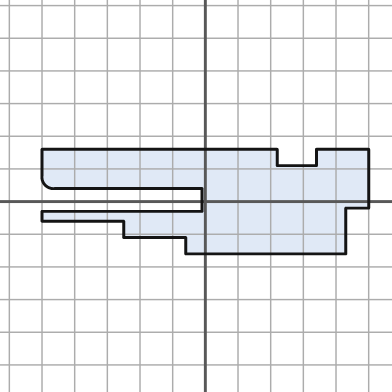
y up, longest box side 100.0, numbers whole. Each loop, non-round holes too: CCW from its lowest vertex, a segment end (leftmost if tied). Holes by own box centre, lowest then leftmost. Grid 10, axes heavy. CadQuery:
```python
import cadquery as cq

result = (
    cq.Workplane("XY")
    .moveTo(-6.0, -16.0)
    .lineTo(43.0, -16.0)
    .lineTo(43.0, -2.0)
    .lineTo(50.0, -2.0)
    .lineTo(50.0, 16.0)
    .lineTo(34.0, 16.0)
    .lineTo(34.0, 11.0)
    .lineTo(22.0, 11.0)
    .lineTo(22.0, 16.0)
    .lineTo(-50.0, 16.0)
    .lineTo(-50.0, 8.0)
    .threePointArc((-49.0, 5.0), (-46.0, 4.0))
    .lineTo(-1.0, 4.0)
    .lineTo(-1.0, -3.0)
    .lineTo(-50.0, -3.0)
    .lineTo(-50.0, -6.0)
    .lineTo(-25.0, -6.0)
    .lineTo(-25.0, -11.0)
    .lineTo(-6.0, -11.0)
    .close()
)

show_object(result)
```